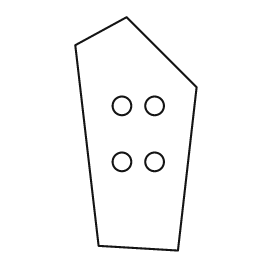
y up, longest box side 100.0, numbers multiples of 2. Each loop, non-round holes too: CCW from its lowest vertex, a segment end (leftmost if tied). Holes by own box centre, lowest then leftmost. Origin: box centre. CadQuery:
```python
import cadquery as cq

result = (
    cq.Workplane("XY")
    .moveTo(18.0, -50.0)
    .lineTo(26.0, 20.0)
    .lineTo(-4.0, 50.0)
    .lineTo(-26.0, 38.0)
    .lineTo(-16.0, -48.0)
    .close()
    .moveTo(-6.0, -12.0)
    .circle(4.0)
    .moveTo(8.0, -12.0)
    .circle(4.0)
    .moveTo(-6.0, 12.0)
    .circle(4.0)
    .moveTo(8.0, 12.0)
    .circle(4.0)
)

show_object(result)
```